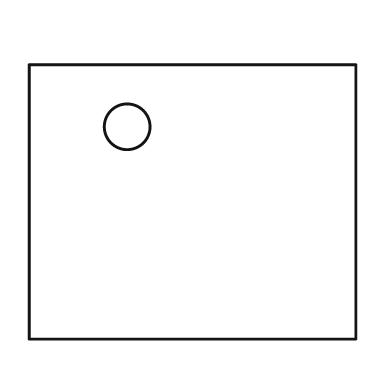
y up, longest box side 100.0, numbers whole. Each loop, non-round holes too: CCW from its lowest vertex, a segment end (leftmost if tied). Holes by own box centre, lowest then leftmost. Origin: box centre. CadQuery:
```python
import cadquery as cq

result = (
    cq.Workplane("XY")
    .moveTo(-50.0, -42.0)
    .lineTo(50.0, -42.0)
    .lineTo(50.0, 42.0)
    .lineTo(-50.0, 42.0)
    .close()
    .moveTo(-20.0, 23.0)
    .circle(7.0)
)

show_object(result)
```